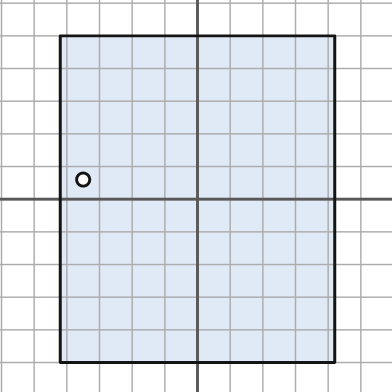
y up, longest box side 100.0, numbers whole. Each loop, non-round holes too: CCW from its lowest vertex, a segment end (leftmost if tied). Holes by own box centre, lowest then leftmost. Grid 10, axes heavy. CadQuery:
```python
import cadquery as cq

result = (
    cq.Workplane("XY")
    .moveTo(-42.0, -50.0)
    .lineTo(42.0, -50.0)
    .lineTo(42.0, 50.0)
    .lineTo(-42.0, 50.0)
    .close()
    .moveTo(-35.0, 6.0)
    .circle(2.0)
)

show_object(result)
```